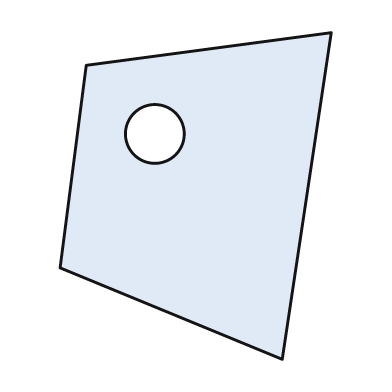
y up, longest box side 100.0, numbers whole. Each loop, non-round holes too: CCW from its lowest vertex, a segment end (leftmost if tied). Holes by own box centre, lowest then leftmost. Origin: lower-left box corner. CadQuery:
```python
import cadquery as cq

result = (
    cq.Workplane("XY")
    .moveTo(68.0, 0.0)
    .lineTo(83.0, 100.0)
    .lineTo(8.0, 90.0)
    .lineTo(0.0, 28.0)
    .close()
    .moveTo(29.0, 69.0)
    .circle(9.0)
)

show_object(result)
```